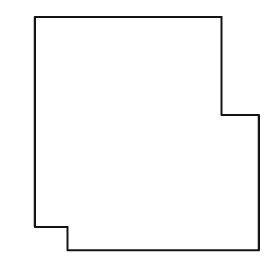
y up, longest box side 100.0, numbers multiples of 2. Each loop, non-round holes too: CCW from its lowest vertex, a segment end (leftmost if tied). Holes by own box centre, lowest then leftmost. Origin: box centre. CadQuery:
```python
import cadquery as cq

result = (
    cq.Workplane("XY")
    .moveTo(-34.0, -50.0)
    .lineTo(48.0, -50.0)
    .lineTo(48.0, 8.0)
    .lineTo(32.0, 8.0)
    .lineTo(32.0, 50.0)
    .lineTo(-48.0, 50.0)
    .lineTo(-48.0, -40.0)
    .lineTo(-34.0, -40.0)
    .close()
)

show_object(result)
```